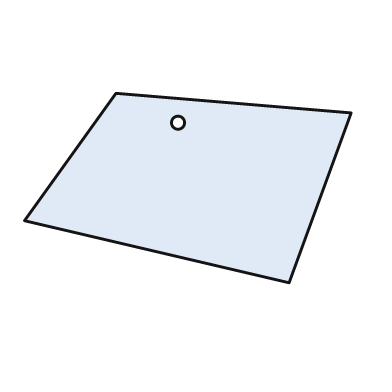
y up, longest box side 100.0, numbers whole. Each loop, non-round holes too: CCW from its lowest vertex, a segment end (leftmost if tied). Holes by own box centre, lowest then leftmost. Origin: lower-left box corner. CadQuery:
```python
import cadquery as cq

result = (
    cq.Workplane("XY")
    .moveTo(81.0, 0.0)
    .lineTo(100.0, 52.0)
    .lineTo(28.0, 58.0)
    .lineTo(0.0, 19.0)
    .close()
    .moveTo(47.0, 49.0)
    .circle(2.0)
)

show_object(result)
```